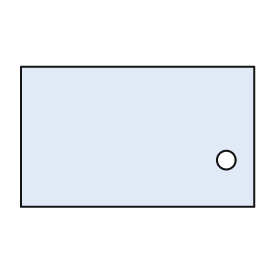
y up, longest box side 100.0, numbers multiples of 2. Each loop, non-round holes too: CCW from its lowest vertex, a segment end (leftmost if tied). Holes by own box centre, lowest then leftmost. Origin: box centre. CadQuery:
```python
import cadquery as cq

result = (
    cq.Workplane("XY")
    .moveTo(-50.0, -30.0)
    .lineTo(50.0, -30.0)
    .lineTo(50.0, 30.0)
    .lineTo(-50.0, 30.0)
    .close()
    .moveTo(38.0, -10.0)
    .circle(4.0)
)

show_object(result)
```